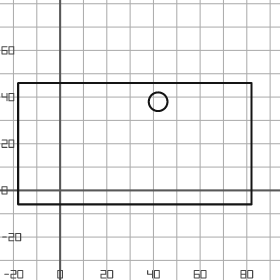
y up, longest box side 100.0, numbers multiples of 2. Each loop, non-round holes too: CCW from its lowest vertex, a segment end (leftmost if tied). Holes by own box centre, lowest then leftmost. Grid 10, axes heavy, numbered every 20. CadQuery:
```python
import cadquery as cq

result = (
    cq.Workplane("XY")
    .moveTo(-18.0, -6.0)
    .lineTo(82.0, -6.0)
    .lineTo(82.0, 46.0)
    .lineTo(-18.0, 46.0)
    .close()
    .moveTo(42.0, 38.0)
    .circle(4.0)
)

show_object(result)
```